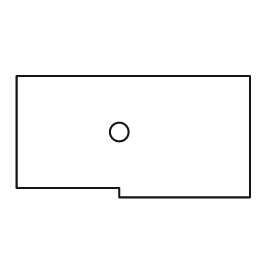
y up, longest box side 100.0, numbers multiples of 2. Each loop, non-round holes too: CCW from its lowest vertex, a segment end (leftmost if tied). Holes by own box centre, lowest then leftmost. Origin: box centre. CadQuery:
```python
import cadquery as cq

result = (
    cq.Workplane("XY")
    .moveTo(-6.0, -26.0)
    .lineTo(50.0, -26.0)
    .lineTo(50.0, 26.0)
    .lineTo(-50.0, 26.0)
    .lineTo(-50.0, -22.0)
    .lineTo(-6.0, -22.0)
    .close()
    .moveTo(-6.0, 2.0)
    .circle(4.0)
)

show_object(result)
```